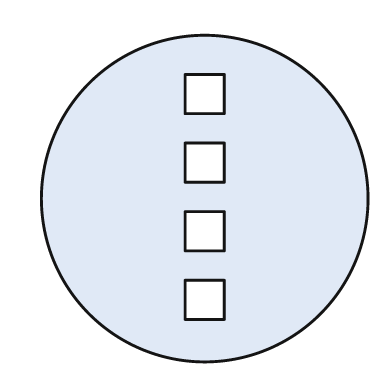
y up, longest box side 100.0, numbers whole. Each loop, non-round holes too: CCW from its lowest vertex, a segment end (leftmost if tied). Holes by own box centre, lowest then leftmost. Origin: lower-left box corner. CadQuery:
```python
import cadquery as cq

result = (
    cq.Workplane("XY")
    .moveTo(50.0, 50.0)
    .circle(50.0)
    .moveTo(44.0, 13.0)
    .lineTo(56.0, 13.0)
    .lineTo(56.0, 25.0)
    .lineTo(44.0, 25.0)
    .close()
    .moveTo(44.0, 34.0)
    .lineTo(56.0, 34.0)
    .lineTo(56.0, 46.0)
    .lineTo(44.0, 46.0)
    .close()
    .moveTo(44.0, 55.0)
    .lineTo(56.0, 55.0)
    .lineTo(56.0, 67.0)
    .lineTo(44.0, 67.0)
    .close()
    .moveTo(44.0, 76.0)
    .lineTo(56.0, 76.0)
    .lineTo(56.0, 88.0)
    .lineTo(44.0, 88.0)
    .close()
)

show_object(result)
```